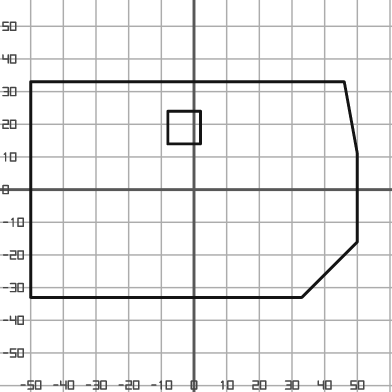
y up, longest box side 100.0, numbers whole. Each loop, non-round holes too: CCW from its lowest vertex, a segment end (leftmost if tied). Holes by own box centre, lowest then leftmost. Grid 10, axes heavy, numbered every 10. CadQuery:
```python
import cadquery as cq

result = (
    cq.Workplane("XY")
    .moveTo(-50.0, -33.0)
    .lineTo(33.0, -33.0)
    .lineTo(50.0, -16.0)
    .lineTo(50.0, 11.0)
    .lineTo(46.0, 33.0)
    .lineTo(-50.0, 33.0)
    .close()
    .moveTo(-8.0, 14.0)
    .lineTo(2.0, 14.0)
    .lineTo(2.0, 24.0)
    .lineTo(-8.0, 24.0)
    .close()
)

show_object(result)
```